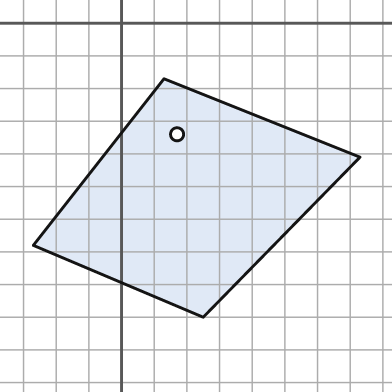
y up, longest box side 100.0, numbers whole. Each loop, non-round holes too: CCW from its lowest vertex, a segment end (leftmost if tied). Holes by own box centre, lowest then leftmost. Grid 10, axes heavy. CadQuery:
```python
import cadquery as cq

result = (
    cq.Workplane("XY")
    .moveTo(25.0, -90.0)
    .lineTo(73.0, -41.0)
    .lineTo(13.0, -17.0)
    .lineTo(-27.0, -68.0)
    .close()
    .moveTo(17.0, -34.0)
    .circle(2.0)
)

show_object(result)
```